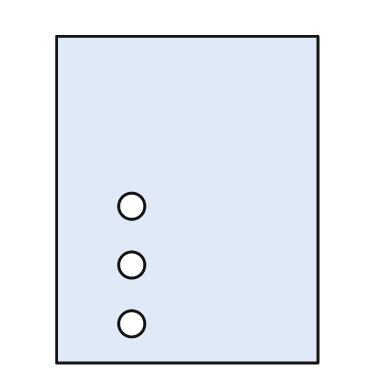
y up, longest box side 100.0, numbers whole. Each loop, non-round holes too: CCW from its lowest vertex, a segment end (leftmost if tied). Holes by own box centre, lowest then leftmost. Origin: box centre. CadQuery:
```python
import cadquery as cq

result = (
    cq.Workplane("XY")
    .moveTo(-40.0, -50.0)
    .lineTo(40.0, -50.0)
    .lineTo(40.0, 50.0)
    .lineTo(-40.0, 50.0)
    .close()
    .moveTo(-17.0, -38.0)
    .circle(4.0)
    .moveTo(-17.0, -20.0)
    .circle(4.0)
    .moveTo(-17.0, -2.0)
    .circle(4.0)
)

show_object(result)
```